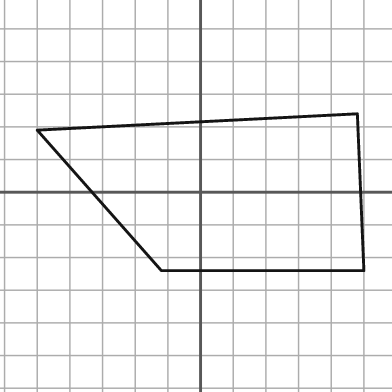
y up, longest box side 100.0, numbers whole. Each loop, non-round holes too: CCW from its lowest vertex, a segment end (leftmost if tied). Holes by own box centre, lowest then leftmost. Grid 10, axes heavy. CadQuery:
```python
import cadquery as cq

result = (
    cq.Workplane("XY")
    .moveTo(-12.0, -24.0)
    .lineTo(50.0, -24.0)
    .lineTo(48.0, 24.0)
    .lineTo(-50.0, 19.0)
    .close()
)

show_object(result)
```